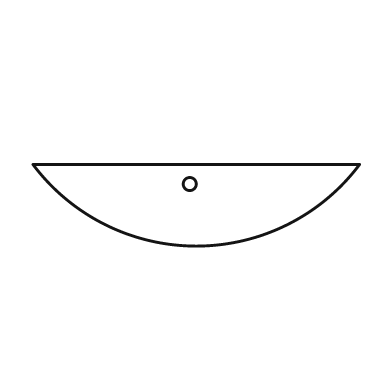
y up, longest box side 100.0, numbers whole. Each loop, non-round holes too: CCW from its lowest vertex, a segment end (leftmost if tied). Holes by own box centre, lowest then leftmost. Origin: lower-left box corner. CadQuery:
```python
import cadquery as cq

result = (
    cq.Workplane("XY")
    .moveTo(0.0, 25.0)
    .threePointArc((50.0, 0.0), (100.0, 25.0))
    .close()
    .moveTo(48.0, 19.0)
    .circle(2.0)
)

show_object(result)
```